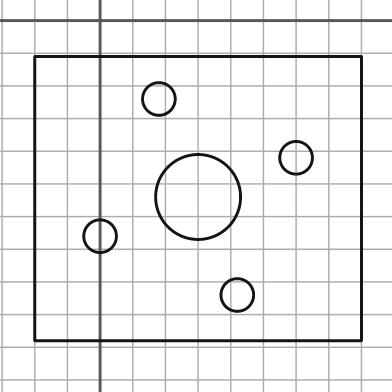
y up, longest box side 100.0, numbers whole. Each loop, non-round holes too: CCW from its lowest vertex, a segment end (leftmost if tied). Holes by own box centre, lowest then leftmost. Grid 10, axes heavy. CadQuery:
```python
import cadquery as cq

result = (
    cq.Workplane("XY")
    .moveTo(-20.0, -98.0)
    .lineTo(80.0, -98.0)
    .lineTo(80.0, -11.0)
    .lineTo(-20.0, -11.0)
    .close()
    .moveTo(42.0, -84.0)
    .circle(5.0)
    .moveTo(0.0, -66.0)
    .circle(5.0)
    .moveTo(30.0, -54.0)
    .circle(13.0)
    .moveTo(60.0, -42.0)
    .circle(5.0)
    .moveTo(18.0, -24.0)
    .circle(5.0)
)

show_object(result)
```